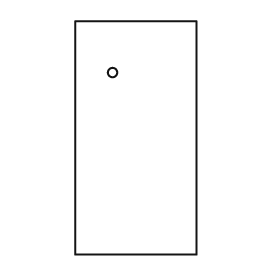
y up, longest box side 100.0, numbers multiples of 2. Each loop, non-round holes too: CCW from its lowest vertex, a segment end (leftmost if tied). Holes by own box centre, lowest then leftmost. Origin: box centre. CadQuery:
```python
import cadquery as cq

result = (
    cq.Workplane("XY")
    .moveTo(-26.0, -50.0)
    .lineTo(26.0, -50.0)
    .lineTo(26.0, 50.0)
    .lineTo(-26.0, 50.0)
    .close()
    .moveTo(-10.0, 28.0)
    .circle(2.0)
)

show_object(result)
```